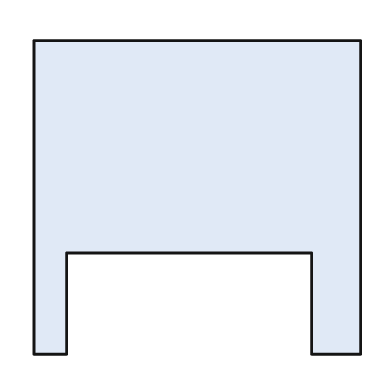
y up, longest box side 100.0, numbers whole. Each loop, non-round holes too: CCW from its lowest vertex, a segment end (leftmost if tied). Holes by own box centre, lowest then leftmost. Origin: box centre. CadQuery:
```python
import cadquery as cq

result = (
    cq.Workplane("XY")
    .moveTo(-50.0, -48.0)
    .lineTo(-40.0, -48.0)
    .lineTo(-40.0, -17.0)
    .lineTo(35.0, -17.0)
    .lineTo(35.0, -48.0)
    .lineTo(50.0, -48.0)
    .lineTo(50.0, 48.0)
    .lineTo(-50.0, 48.0)
    .close()
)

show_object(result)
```